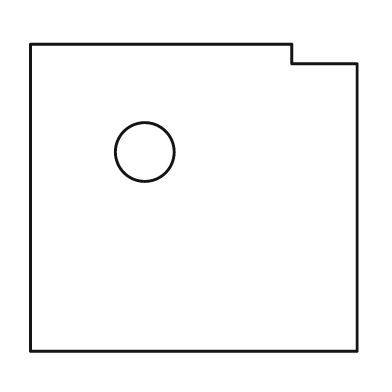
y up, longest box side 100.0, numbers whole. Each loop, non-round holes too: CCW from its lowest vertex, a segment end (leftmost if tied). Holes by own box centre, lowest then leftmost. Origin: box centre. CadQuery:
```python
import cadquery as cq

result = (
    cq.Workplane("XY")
    .moveTo(-50.0, -47.0)
    .lineTo(50.0, -47.0)
    .lineTo(50.0, 41.0)
    .lineTo(30.0, 41.0)
    .lineTo(30.0, 47.0)
    .lineTo(-50.0, 47.0)
    .close()
    .moveTo(-15.0, 14.0)
    .circle(9.0)
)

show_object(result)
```